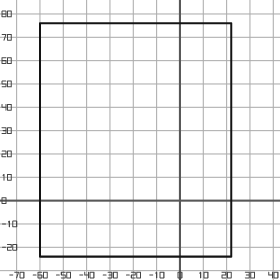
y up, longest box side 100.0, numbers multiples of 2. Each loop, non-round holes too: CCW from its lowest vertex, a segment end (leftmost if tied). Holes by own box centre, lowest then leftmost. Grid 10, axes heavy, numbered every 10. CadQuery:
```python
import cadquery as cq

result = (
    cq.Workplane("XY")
    .moveTo(-60.0, -24.0)
    .lineTo(22.0, -24.0)
    .lineTo(22.0, 76.0)
    .lineTo(-60.0, 76.0)
    .close()
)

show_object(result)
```